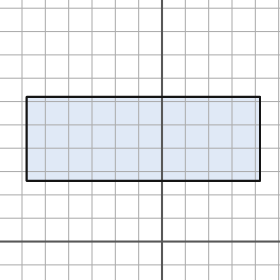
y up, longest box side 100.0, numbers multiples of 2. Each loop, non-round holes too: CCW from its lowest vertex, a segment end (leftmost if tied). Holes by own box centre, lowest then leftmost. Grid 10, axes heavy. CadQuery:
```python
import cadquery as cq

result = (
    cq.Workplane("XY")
    .moveTo(-58.0, 26.0)
    .lineTo(42.0, 26.0)
    .lineTo(42.0, 62.0)
    .lineTo(-58.0, 62.0)
    .close()
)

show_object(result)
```